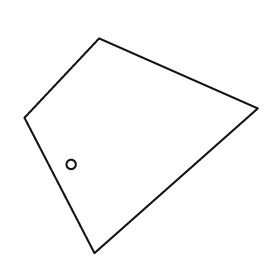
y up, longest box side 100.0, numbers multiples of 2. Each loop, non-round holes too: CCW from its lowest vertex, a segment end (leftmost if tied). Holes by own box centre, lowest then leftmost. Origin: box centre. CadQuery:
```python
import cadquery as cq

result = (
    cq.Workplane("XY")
    .moveTo(-20.0, -46.0)
    .lineTo(50.0, 16.0)
    .lineTo(-18.0, 46.0)
    .lineTo(-50.0, 12.0)
    .close()
    .moveTo(-30.0, -8.0)
    .circle(2.0)
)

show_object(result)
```